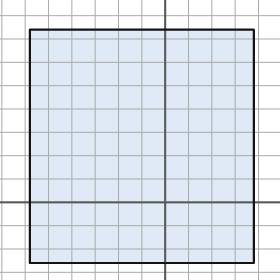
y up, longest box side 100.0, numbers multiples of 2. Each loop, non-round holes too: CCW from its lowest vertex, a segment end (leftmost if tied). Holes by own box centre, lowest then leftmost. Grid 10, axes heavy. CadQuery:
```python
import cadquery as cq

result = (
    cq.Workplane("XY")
    .moveTo(-58.0, -26.0)
    .lineTo(38.0, -26.0)
    .lineTo(38.0, 74.0)
    .lineTo(-58.0, 74.0)
    .close()
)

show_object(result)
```